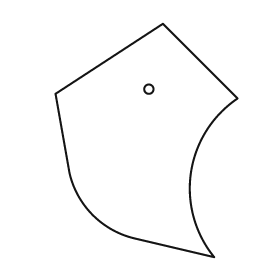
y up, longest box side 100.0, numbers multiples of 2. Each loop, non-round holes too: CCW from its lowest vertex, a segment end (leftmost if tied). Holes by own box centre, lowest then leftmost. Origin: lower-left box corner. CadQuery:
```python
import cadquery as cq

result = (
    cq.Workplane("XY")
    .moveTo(68.0, 0.0)
    .threePointArc((58.0, 36.0), (78.0, 68.0))
    .lineTo(46.0, 100.0)
    .lineTo(0.0, 70.0)
    .lineTo(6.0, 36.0)
    .threePointArc((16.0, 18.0), (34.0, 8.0))
    .close()
    .moveTo(40.0, 72.0)
    .circle(2.0)
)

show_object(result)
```